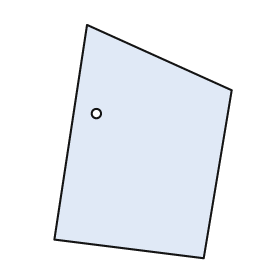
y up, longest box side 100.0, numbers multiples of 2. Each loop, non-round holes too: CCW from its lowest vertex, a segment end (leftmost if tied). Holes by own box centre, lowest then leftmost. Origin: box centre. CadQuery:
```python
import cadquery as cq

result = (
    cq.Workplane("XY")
    .moveTo(26.0, -50.0)
    .lineTo(38.0, 22.0)
    .lineTo(-24.0, 50.0)
    .lineTo(-38.0, -42.0)
    .close()
    .moveTo(-20.0, 12.0)
    .circle(2.0)
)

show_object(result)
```